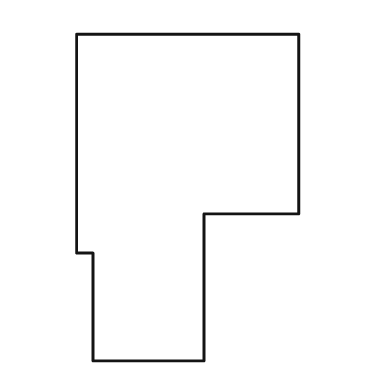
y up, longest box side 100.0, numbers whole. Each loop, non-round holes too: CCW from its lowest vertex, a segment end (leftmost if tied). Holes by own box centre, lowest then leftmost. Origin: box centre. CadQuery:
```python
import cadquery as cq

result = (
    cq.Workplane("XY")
    .moveTo(-29.0, -50.0)
    .lineTo(5.0, -50.0)
    .lineTo(5.0, -5.0)
    .lineTo(34.0, -5.0)
    .lineTo(34.0, 50.0)
    .lineTo(-34.0, 50.0)
    .lineTo(-34.0, -17.0)
    .lineTo(-29.0, -17.0)
    .close()
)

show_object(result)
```